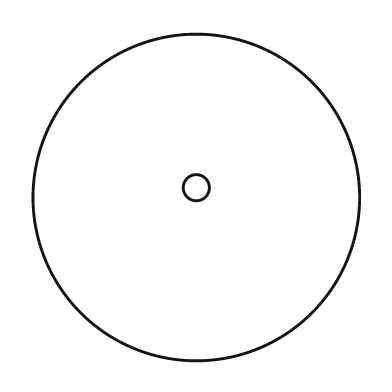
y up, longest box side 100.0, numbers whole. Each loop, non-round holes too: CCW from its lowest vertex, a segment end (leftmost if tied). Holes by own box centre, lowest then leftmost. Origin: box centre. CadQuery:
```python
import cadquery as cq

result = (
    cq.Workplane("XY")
    .moveTo(0.0, 0.0)
    .circle(50.0)
    .moveTo(0.0, 3.0)
    .circle(4.0)
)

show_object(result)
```